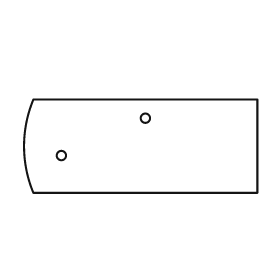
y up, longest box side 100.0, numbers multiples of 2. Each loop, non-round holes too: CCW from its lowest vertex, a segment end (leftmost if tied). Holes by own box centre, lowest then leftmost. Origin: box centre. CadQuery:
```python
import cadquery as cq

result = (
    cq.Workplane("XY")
    .moveTo(-46.0, -20.0)
    .lineTo(50.0, -20.0)
    .lineTo(50.0, 20.0)
    .lineTo(-46.0, 20.0)
    .threePointArc((-50.0, 0.0), (-46.0, -20.0))
    .close()
    .moveTo(-34.0, -4.0)
    .circle(2.0)
    .moveTo(2.0, 12.0)
    .circle(2.0)
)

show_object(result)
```